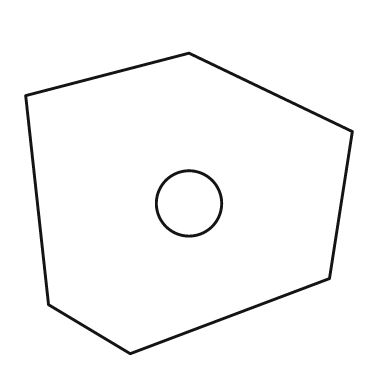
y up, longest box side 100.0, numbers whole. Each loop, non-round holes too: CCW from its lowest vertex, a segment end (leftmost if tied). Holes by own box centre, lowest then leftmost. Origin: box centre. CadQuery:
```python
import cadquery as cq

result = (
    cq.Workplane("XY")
    .moveTo(-18.0, -46.0)
    .lineTo(43.0, -23.0)
    .lineTo(50.0, 22.0)
    .lineTo(0.0, 46.0)
    .lineTo(-50.0, 33.0)
    .lineTo(-43.0, -31.0)
    .close()
    .moveTo(0.0, 0.0)
    .circle(10.0)
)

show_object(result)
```